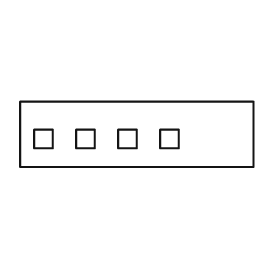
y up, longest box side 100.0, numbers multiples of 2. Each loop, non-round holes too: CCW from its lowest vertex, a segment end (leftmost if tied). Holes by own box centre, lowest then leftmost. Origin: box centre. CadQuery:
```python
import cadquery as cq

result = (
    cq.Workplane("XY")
    .moveTo(-50.0, -14.0)
    .lineTo(50.0, -14.0)
    .lineTo(50.0, 14.0)
    .lineTo(-50.0, 14.0)
    .close()
    .moveTo(-44.0, -6.0)
    .lineTo(-36.0, -6.0)
    .lineTo(-36.0, 2.0)
    .lineTo(-44.0, 2.0)
    .close()
    .moveTo(-26.0, -6.0)
    .lineTo(-18.0, -6.0)
    .lineTo(-18.0, 2.0)
    .lineTo(-26.0, 2.0)
    .close()
    .moveTo(-8.0, -6.0)
    .lineTo(0.0, -6.0)
    .lineTo(0.0, 2.0)
    .lineTo(-8.0, 2.0)
    .close()
    .moveTo(10.0, -6.0)
    .lineTo(18.0, -6.0)
    .lineTo(18.0, 2.0)
    .lineTo(10.0, 2.0)
    .close()
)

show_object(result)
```